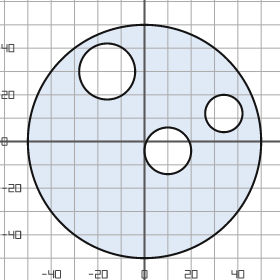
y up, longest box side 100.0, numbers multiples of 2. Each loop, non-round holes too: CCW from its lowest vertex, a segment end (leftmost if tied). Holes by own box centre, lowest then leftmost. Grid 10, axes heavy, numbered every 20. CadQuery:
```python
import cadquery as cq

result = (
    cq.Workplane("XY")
    .moveTo(0.0, 0.0)
    .circle(50.0)
    .moveTo(10.0, -4.0)
    .circle(10.0)
    .moveTo(34.0, 12.0)
    .circle(8.0)
    .moveTo(-16.0, 30.0)
    .circle(12.0)
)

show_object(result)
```